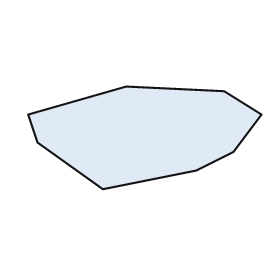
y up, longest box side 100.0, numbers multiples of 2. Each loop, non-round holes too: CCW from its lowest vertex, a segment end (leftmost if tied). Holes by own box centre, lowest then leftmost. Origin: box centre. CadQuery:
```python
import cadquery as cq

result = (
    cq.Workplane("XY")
    .moveTo(-18.0, -22.0)
    .lineTo(22.0, -14.0)
    .lineTo(38.0, -6.0)
    .lineTo(50.0, 10.0)
    .lineTo(34.0, 20.0)
    .lineTo(-8.0, 22.0)
    .lineTo(-50.0, 10.0)
    .lineTo(-46.0, -2.0)
    .close()
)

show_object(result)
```